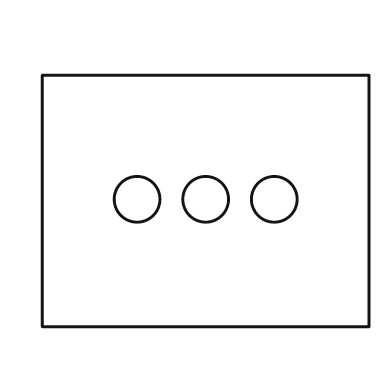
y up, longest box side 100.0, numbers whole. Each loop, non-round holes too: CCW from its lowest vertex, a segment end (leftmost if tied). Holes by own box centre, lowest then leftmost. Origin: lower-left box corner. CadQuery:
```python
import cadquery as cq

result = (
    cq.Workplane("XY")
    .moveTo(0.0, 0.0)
    .lineTo(100.0, 0.0)
    .lineTo(100.0, 77.0)
    .lineTo(0.0, 77.0)
    .close()
    .moveTo(29.0, 39.0)
    .circle(7.0)
    .moveTo(50.0, 39.0)
    .circle(7.0)
    .moveTo(71.0, 39.0)
    .circle(7.0)
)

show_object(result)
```